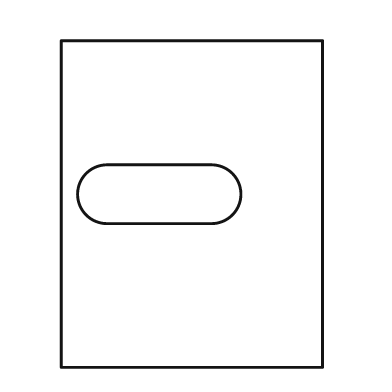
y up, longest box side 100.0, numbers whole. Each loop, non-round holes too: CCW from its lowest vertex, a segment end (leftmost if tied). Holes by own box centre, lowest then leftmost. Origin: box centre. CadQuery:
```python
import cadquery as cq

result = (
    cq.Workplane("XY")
    .moveTo(-40.0, -50.0)
    .lineTo(40.0, -50.0)
    .lineTo(40.0, 50.0)
    .lineTo(-40.0, 50.0)
    .close()
    .moveTo(-26.0, -6.0)
    .lineTo(6.0, -6.0)
    .threePointArc((15.0, 3.0), (6.0, 12.0))
    .lineTo(-26.0, 12.0)
    .threePointArc((-35.0, 3.0), (-26.0, -6.0))
    .close()
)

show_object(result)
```